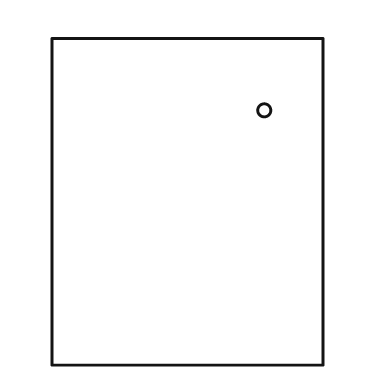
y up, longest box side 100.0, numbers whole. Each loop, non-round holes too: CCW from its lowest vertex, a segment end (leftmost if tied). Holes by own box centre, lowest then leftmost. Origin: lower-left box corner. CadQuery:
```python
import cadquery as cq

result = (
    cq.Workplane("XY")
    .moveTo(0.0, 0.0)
    .lineTo(83.0, 0.0)
    .lineTo(83.0, 100.0)
    .lineTo(0.0, 100.0)
    .close()
    .moveTo(65.0, 78.0)
    .circle(2.0)
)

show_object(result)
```